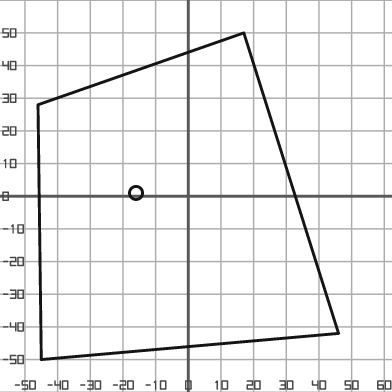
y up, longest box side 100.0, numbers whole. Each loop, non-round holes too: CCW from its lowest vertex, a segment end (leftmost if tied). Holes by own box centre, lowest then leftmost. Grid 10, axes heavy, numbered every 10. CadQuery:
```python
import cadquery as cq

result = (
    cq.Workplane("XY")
    .moveTo(-45.0, -50.0)
    .lineTo(46.0, -42.0)
    .lineTo(17.0, 50.0)
    .lineTo(-46.0, 28.0)
    .close()
    .moveTo(-16.0, 1.0)
    .circle(2.0)
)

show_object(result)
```